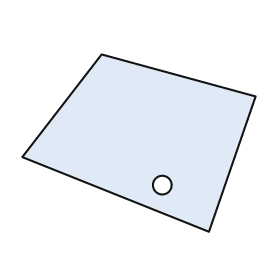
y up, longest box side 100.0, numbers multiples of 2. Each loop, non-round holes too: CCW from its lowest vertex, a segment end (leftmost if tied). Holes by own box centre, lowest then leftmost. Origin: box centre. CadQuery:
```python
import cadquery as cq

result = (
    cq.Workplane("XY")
    .moveTo(30.0, -38.0)
    .lineTo(50.0, 20.0)
    .lineTo(-16.0, 38.0)
    .lineTo(-50.0, -6.0)
    .close()
    .moveTo(10.0, -18.0)
    .circle(4.0)
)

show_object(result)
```